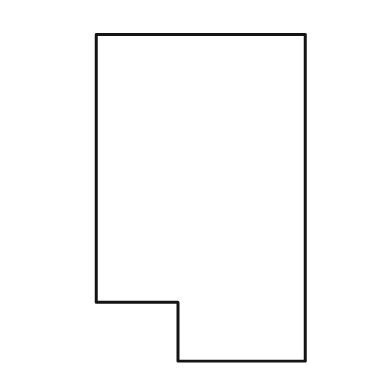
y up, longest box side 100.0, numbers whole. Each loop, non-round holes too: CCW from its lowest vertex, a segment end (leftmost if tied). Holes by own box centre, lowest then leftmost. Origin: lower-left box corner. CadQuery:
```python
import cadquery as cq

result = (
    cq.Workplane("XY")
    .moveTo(25.0, 0.0)
    .lineTo(64.0, 0.0)
    .lineTo(64.0, 100.0)
    .lineTo(0.0, 100.0)
    .lineTo(0.0, 18.0)
    .lineTo(25.0, 18.0)
    .close()
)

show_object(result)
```